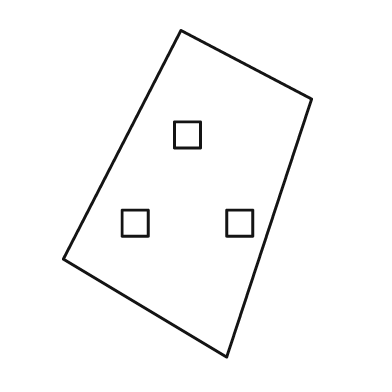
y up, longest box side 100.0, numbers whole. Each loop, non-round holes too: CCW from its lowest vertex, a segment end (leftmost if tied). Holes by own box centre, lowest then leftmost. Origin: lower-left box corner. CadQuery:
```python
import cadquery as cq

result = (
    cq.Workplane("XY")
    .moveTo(50.0, 0.0)
    .lineTo(76.0, 79.0)
    .lineTo(36.0, 100.0)
    .lineTo(0.0, 30.0)
    .close()
    .moveTo(18.0, 37.0)
    .lineTo(26.0, 37.0)
    .lineTo(26.0, 45.0)
    .lineTo(18.0, 45.0)
    .close()
    .moveTo(50.0, 37.0)
    .lineTo(58.0, 37.0)
    .lineTo(58.0, 45.0)
    .lineTo(50.0, 45.0)
    .close()
    .moveTo(34.0, 64.0)
    .lineTo(42.0, 64.0)
    .lineTo(42.0, 72.0)
    .lineTo(34.0, 72.0)
    .close()
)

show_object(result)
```